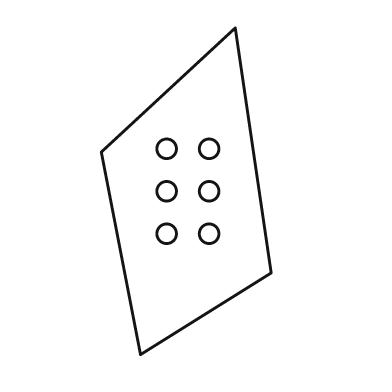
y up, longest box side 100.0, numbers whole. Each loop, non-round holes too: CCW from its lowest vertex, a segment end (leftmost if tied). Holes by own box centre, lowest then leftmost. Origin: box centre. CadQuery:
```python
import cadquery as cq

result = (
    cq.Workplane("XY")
    .moveTo(-14.0, -50.0)
    .lineTo(26.0, -25.0)
    .lineTo(15.0, 50.0)
    .lineTo(-26.0, 12.0)
    .close()
    .moveTo(-6.0, -13.0)
    .circle(3.0)
    .moveTo(7.0, -13.0)
    .circle(3.0)
    .moveTo(-6.0, 0.0)
    .circle(3.0)
    .moveTo(7.0, 0.0)
    .circle(3.0)
    .moveTo(-6.0, 13.0)
    .circle(3.0)
    .moveTo(7.0, 13.0)
    .circle(3.0)
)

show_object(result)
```